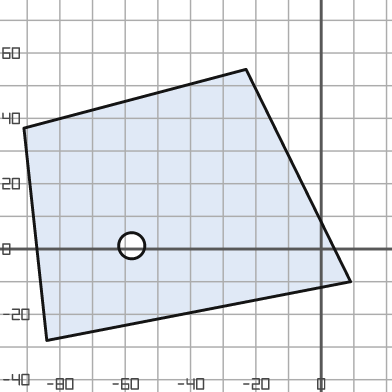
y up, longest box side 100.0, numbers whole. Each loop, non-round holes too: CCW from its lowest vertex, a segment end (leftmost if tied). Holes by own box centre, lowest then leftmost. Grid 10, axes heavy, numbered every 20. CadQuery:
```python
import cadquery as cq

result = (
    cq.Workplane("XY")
    .moveTo(-84.0, -28.0)
    .lineTo(9.0, -10.0)
    .lineTo(-23.0, 55.0)
    .lineTo(-91.0, 37.0)
    .close()
    .moveTo(-58.0, 1.0)
    .circle(4.0)
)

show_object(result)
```